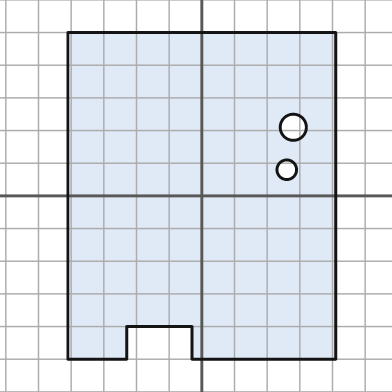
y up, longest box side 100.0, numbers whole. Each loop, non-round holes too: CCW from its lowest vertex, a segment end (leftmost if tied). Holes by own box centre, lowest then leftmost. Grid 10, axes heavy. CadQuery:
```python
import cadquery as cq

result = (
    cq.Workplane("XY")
    .moveTo(-41.0, -50.0)
    .lineTo(-23.0, -50.0)
    .lineTo(-23.0, -40.0)
    .lineTo(-3.0, -40.0)
    .lineTo(-3.0, -50.0)
    .lineTo(41.0, -50.0)
    .lineTo(41.0, 50.0)
    .lineTo(-41.0, 50.0)
    .close()
    .moveTo(26.0, 8.0)
    .circle(3.0)
    .moveTo(28.0, 21.0)
    .circle(4.0)
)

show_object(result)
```